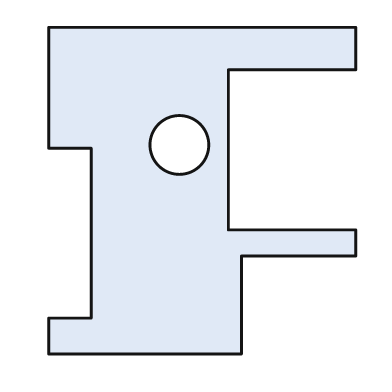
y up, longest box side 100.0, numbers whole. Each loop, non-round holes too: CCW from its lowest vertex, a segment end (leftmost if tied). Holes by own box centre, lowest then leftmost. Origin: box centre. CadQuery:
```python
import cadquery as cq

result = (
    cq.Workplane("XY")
    .moveTo(-47.0, -50.0)
    .lineTo(12.0, -50.0)
    .lineTo(12.0, -20.0)
    .lineTo(47.0, -20.0)
    .lineTo(47.0, -12.0)
    .lineTo(8.0, -12.0)
    .lineTo(8.0, 37.0)
    .lineTo(47.0, 37.0)
    .lineTo(47.0, 50.0)
    .lineTo(-47.0, 50.0)
    .lineTo(-47.0, 13.0)
    .lineTo(-34.0, 13.0)
    .lineTo(-34.0, -39.0)
    .lineTo(-47.0, -39.0)
    .close()
    .moveTo(-7.0, 14.0)
    .circle(9.0)
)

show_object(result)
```